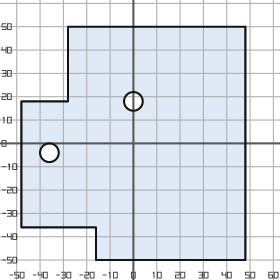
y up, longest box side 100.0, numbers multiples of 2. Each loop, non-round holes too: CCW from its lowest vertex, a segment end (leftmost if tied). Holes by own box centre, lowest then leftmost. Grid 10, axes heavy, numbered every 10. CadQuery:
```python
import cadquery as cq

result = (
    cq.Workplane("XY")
    .moveTo(-16.0, -50.0)
    .lineTo(48.0, -50.0)
    .lineTo(48.0, 50.0)
    .lineTo(-28.0, 50.0)
    .lineTo(-28.0, 18.0)
    .lineTo(-48.0, 18.0)
    .lineTo(-48.0, -36.0)
    .lineTo(-16.0, -36.0)
    .close()
    .moveTo(-36.0, -4.0)
    .circle(4.0)
    .moveTo(0.0, 18.0)
    .circle(4.0)
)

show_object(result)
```